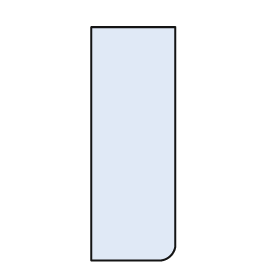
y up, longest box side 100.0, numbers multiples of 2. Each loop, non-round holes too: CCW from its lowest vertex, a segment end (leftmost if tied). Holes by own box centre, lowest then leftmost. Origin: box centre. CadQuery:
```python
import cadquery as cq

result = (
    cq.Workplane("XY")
    .moveTo(-18.0, -50.0)
    .lineTo(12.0, -50.0)
    .threePointArc((16.0, -48.0), (18.0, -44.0))
    .lineTo(18.0, 50.0)
    .lineTo(-18.0, 50.0)
    .close()
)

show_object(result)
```